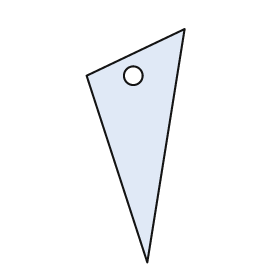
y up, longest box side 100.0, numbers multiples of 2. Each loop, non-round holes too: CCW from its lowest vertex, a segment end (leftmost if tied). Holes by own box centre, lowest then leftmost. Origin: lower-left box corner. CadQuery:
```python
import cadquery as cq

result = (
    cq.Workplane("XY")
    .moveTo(26.0, 0.0)
    .lineTo(42.0, 100.0)
    .lineTo(0.0, 80.0)
    .close()
    .moveTo(20.0, 80.0)
    .circle(4.0)
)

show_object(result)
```